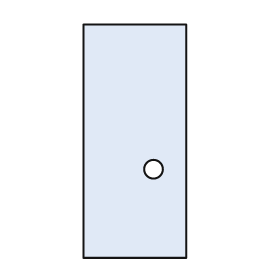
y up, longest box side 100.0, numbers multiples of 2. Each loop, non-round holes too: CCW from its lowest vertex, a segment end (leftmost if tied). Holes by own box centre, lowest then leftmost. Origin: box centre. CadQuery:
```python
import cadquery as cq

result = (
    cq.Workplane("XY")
    .moveTo(-22.0, -50.0)
    .lineTo(22.0, -50.0)
    .lineTo(22.0, 50.0)
    .lineTo(-22.0, 50.0)
    .close()
    .moveTo(8.0, -12.0)
    .circle(4.0)
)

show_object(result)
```